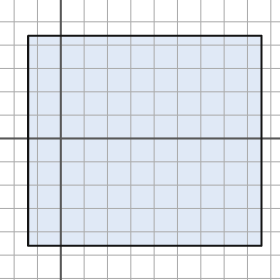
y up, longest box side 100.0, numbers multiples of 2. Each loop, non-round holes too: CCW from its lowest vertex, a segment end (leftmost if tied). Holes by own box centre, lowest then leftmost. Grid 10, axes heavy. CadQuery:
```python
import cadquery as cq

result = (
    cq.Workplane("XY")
    .moveTo(-14.0, -46.0)
    .lineTo(86.0, -46.0)
    .lineTo(86.0, 44.0)
    .lineTo(-14.0, 44.0)
    .close()
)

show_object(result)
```